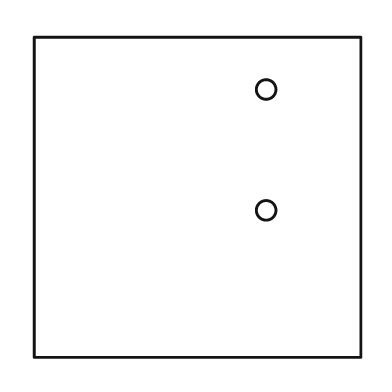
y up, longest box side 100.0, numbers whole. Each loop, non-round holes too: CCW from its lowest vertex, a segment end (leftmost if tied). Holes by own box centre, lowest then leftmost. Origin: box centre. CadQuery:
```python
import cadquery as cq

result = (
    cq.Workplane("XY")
    .moveTo(-50.0, -49.0)
    .lineTo(50.0, -49.0)
    .lineTo(50.0, 49.0)
    .lineTo(-50.0, 49.0)
    .close()
    .moveTo(21.0, -4.0)
    .circle(3.0)
    .moveTo(21.0, 33.0)
    .circle(3.0)
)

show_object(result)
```